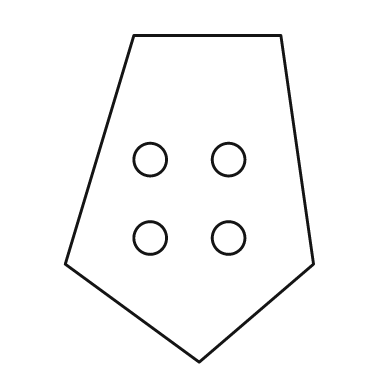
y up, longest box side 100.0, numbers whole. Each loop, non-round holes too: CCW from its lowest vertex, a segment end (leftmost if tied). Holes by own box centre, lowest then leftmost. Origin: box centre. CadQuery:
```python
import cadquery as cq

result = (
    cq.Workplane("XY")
    .moveTo(3.0, -50.0)
    .lineTo(38.0, -20.0)
    .lineTo(28.0, 50.0)
    .lineTo(-17.0, 50.0)
    .lineTo(-38.0, -20.0)
    .close()
    .moveTo(-12.0, -12.0)
    .circle(5.0)
    .moveTo(12.0, -12.0)
    .circle(5.0)
    .moveTo(-12.0, 12.0)
    .circle(5.0)
    .moveTo(12.0, 12.0)
    .circle(5.0)
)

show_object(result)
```